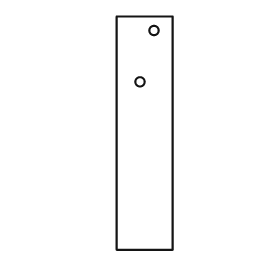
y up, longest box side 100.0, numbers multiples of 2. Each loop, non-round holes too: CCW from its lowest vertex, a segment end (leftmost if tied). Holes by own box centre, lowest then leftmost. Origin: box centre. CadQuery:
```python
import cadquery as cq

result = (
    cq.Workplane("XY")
    .moveTo(-12.0, -50.0)
    .lineTo(12.0, -50.0)
    .lineTo(12.0, 50.0)
    .lineTo(-12.0, 50.0)
    .close()
    .moveTo(-2.0, 22.0)
    .circle(2.0)
    .moveTo(4.0, 44.0)
    .circle(2.0)
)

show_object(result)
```